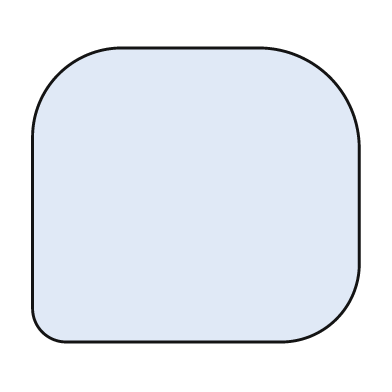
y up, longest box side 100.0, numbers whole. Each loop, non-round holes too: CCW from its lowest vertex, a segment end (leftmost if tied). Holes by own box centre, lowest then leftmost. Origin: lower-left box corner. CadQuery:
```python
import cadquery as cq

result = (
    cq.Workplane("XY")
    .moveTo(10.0, 0.0)
    .lineTo(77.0, 0.0)
    .threePointArc((93.0, 7.0), (100.0, 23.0))
    .lineTo(100.0, 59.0)
    .threePointArc((91.0, 81.0), (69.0, 90.0))
    .lineTo(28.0, 90.0)
    .threePointArc((8.0, 82.0), (0.0, 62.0))
    .lineTo(0.0, 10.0)
    .threePointArc((3.0, 3.0), (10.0, 0.0))
    .close()
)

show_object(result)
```